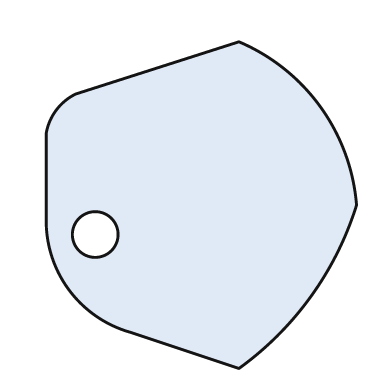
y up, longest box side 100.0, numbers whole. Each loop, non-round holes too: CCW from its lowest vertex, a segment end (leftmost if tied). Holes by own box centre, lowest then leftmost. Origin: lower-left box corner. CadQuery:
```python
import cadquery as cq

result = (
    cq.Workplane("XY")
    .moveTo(59.0, 0.0)
    .threePointArc((81.0, 22.0), (95.0, 50.0))
    .threePointArc((84.0, 80.0), (59.0, 100.0))
    .lineTo(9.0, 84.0)
    .threePointArc((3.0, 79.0), (0.0, 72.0))
    .lineTo(0.0, 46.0)
    .threePointArc((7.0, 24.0), (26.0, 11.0))
    .close()
    .moveTo(15.0, 41.0)
    .circle(7.0)
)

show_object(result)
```